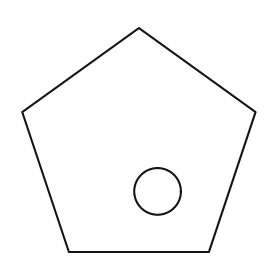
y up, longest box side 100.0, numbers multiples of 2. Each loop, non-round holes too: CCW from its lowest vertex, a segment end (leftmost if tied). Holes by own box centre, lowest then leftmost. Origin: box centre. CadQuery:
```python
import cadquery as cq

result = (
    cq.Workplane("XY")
    .moveTo(-30.0, -48.0)
    .lineTo(30.0, -48.0)
    .lineTo(50.0, 12.0)
    .lineTo(0.0, 48.0)
    .lineTo(-50.0, 12.0)
    .close()
    .moveTo(8.0, -22.0)
    .circle(10.0)
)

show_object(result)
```